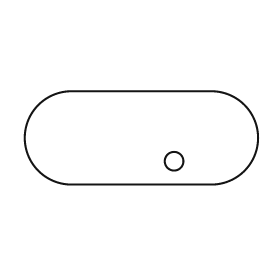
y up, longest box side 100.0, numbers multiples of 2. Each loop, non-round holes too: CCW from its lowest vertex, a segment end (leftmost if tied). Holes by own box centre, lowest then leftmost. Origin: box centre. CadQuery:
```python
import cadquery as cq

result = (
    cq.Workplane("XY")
    .moveTo(-30.0, -20.0)
    .lineTo(30.0, -20.0)
    .threePointArc((50.0, 0.0), (30.0, 20.0))
    .lineTo(-30.0, 20.0)
    .threePointArc((-50.0, 0.0), (-30.0, -20.0))
    .close()
    .moveTo(14.0, -10.0)
    .circle(4.0)
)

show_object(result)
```